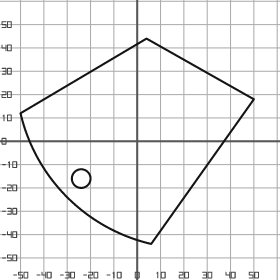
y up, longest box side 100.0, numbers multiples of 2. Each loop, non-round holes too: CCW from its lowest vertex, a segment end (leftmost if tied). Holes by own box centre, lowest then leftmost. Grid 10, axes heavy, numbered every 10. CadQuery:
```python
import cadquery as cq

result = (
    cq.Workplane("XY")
    .moveTo(6.0, -44.0)
    .lineTo(50.0, 18.0)
    .lineTo(4.0, 44.0)
    .lineTo(-50.0, 12.0)
    .threePointArc((-30.0, -24.0), (6.0, -44.0))
    .close()
    .moveTo(-24.0, -16.0)
    .circle(4.0)
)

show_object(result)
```